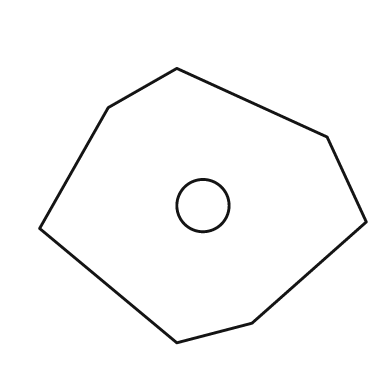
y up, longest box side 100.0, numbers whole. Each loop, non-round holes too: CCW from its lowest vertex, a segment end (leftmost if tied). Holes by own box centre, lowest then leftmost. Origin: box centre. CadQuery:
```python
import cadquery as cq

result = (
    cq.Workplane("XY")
    .moveTo(-8.0, -42.0)
    .lineTo(15.0, -36.0)
    .lineTo(50.0, -5.0)
    .lineTo(38.0, 21.0)
    .lineTo(-8.0, 42.0)
    .lineTo(-29.0, 30.0)
    .lineTo(-50.0, -7.0)
    .close()
    .moveTo(0.0, 0.0)
    .circle(8.0)
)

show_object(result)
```